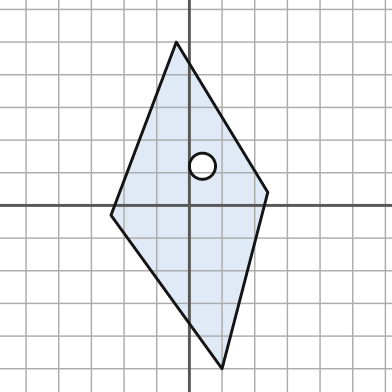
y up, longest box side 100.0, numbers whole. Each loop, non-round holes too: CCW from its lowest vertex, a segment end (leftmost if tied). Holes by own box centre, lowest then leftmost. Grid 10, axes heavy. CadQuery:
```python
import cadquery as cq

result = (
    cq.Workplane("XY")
    .moveTo(10.0, -50.0)
    .lineTo(24.0, 4.0)
    .lineTo(-4.0, 50.0)
    .lineTo(-24.0, -3.0)
    .close()
    .moveTo(4.0, 12.0)
    .circle(4.0)
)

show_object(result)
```